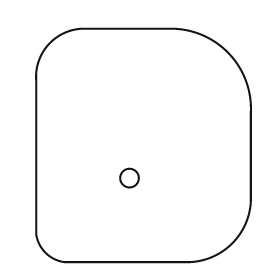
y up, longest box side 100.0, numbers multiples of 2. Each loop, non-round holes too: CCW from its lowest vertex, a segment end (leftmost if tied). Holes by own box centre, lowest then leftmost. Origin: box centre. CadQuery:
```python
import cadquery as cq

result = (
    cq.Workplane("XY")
    .moveTo(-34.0, -50.0)
    .lineTo(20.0, -50.0)
    .threePointArc((38.0, -42.0), (46.0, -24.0))
    .lineTo(46.0, 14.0)
    .threePointArc((36.0, 40.0), (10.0, 50.0))
    .lineTo(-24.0, 50.0)
    .threePointArc((-40.0, 44.0), (-46.0, 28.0))
    .lineTo(-46.0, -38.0)
    .threePointArc((-42.0, -46.0), (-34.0, -50.0))
    .close()
    .moveTo(-6.0, -14.0)
    .circle(4.0)
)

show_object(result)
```